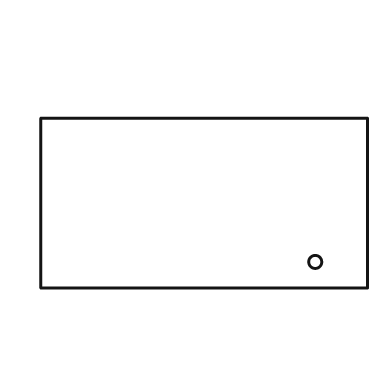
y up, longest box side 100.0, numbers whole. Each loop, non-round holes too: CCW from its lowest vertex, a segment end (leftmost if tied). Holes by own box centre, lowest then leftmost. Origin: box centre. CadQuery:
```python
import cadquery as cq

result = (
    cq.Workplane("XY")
    .moveTo(-50.0, -26.0)
    .lineTo(50.0, -26.0)
    .lineTo(50.0, 26.0)
    .lineTo(-50.0, 26.0)
    .close()
    .moveTo(34.0, -18.0)
    .circle(2.0)
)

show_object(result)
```